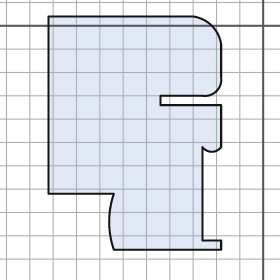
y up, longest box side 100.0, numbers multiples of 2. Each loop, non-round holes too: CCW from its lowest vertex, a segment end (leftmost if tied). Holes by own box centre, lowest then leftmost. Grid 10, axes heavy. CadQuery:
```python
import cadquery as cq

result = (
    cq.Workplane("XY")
    .moveTo(-64.0, -96.0)
    .lineTo(-18.0, -96.0)
    .lineTo(-18.0, -92.0)
    .lineTo(-26.0, -92.0)
    .lineTo(-26.0, -52.0)
    .threePointArc((-22.0, -54.0), (-18.0, -52.0))
    .lineTo(-18.0, -34.0)
    .lineTo(-44.0, -34.0)
    .lineTo(-44.0, -30.0)
    .lineTo(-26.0, -30.0)
    .threePointArc((-20.0, -28.0), (-18.0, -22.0))
    .lineTo(-18.0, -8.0)
    .threePointArc((-22.0, 0.0), (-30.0, 4.0))
    .lineTo(-92.0, 4.0)
    .lineTo(-92.0, -72.0)
    .lineTo(-64.0, -72.0)
    .threePointArc((-66.0, -84.0), (-64.0, -96.0))
    .close()
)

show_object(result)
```